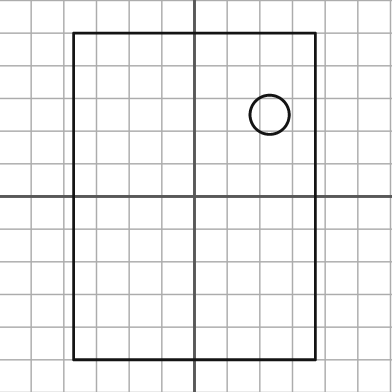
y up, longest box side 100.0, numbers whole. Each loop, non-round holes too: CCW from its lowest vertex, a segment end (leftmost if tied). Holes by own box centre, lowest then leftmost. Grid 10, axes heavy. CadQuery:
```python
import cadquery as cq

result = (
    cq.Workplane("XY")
    .moveTo(-37.0, -50.0)
    .lineTo(37.0, -50.0)
    .lineTo(37.0, 50.0)
    .lineTo(-37.0, 50.0)
    .close()
    .moveTo(23.0, 25.0)
    .circle(6.0)
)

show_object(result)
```